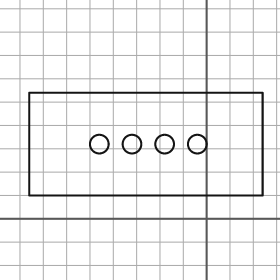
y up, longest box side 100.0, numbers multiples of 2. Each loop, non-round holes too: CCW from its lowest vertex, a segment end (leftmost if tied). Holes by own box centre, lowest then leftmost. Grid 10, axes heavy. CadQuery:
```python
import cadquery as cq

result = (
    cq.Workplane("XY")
    .moveTo(-76.0, 10.0)
    .lineTo(24.0, 10.0)
    .lineTo(24.0, 54.0)
    .lineTo(-76.0, 54.0)
    .close()
    .moveTo(-46.0, 32.0)
    .circle(4.0)
    .moveTo(-32.0, 32.0)
    .circle(4.0)
    .moveTo(-18.0, 32.0)
    .circle(4.0)
    .moveTo(-4.0, 32.0)
    .circle(4.0)
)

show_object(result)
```